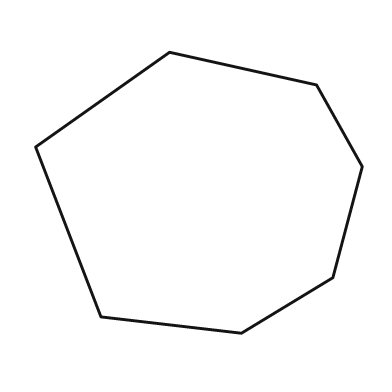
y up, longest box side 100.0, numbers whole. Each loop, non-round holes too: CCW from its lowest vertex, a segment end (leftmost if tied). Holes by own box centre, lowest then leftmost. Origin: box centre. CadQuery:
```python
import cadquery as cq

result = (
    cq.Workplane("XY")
    .moveTo(13.0, -43.0)
    .lineTo(41.0, -26.0)
    .lineTo(50.0, 8.0)
    .lineTo(36.0, 33.0)
    .lineTo(-9.0, 43.0)
    .lineTo(-50.0, 14.0)
    .lineTo(-30.0, -38.0)
    .close()
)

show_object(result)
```